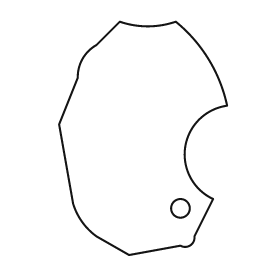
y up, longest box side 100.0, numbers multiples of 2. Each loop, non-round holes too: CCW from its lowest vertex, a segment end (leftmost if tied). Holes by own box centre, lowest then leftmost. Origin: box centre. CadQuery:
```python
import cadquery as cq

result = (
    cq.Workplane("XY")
    .moveTo(-6.0, -50.0)
    .lineTo(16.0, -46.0)
    .threePointArc((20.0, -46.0), (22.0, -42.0))
    .lineTo(30.0, -26.0)
    .threePointArc((18.0, -4.0), (36.0, 14.0))
    .threePointArc((28.0, 34.0), (14.0, 50.0))
    .threePointArc((2.0, 48.0), (-10.0, 50.0))
    .lineTo(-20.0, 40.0)
    .threePointArc((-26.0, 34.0), (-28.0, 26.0))
    .lineTo(-36.0, 6.0)
    .lineTo(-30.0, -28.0)
    .threePointArc((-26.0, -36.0), (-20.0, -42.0))
    .close()
    .moveTo(16.0, -30.0)
    .circle(4.0)
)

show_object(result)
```